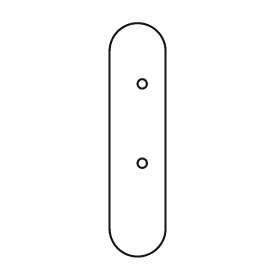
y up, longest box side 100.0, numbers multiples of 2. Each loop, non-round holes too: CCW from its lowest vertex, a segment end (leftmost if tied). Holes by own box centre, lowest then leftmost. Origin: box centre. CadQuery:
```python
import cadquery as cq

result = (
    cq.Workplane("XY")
    .moveTo(-12.0, -38.0)
    .threePointArc((0.0, -50.0), (12.0, -38.0))
    .lineTo(12.0, 38.0)
    .threePointArc((0.0, 50.0), (-12.0, 38.0))
    .close()
    .moveTo(2.0, -10.0)
    .circle(2.0)
    .moveTo(2.0, 24.0)
    .circle(2.0)
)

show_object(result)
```